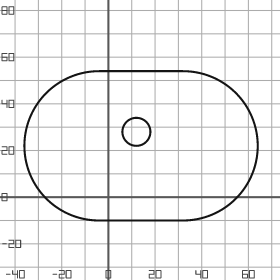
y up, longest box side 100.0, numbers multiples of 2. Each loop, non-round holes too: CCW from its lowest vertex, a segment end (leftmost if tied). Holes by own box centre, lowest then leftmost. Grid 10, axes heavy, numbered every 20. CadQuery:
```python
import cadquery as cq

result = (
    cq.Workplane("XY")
    .moveTo(-4.0, -10.0)
    .lineTo(32.0, -10.0)
    .threePointArc((64.0, 22.0), (32.0, 54.0))
    .lineTo(-4.0, 54.0)
    .threePointArc((-36.0, 22.0), (-4.0, -10.0))
    .close()
    .moveTo(12.0, 28.0)
    .circle(6.0)
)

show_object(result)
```